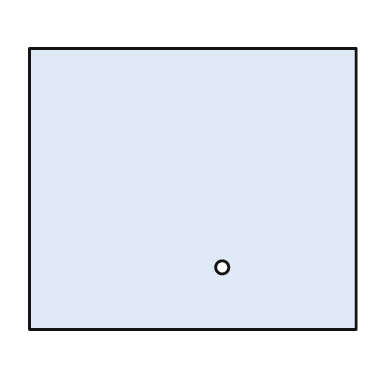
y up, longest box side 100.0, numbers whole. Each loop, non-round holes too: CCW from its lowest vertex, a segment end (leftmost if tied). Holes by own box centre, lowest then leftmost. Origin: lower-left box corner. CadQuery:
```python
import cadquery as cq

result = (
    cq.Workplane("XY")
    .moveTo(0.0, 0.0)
    .lineTo(100.0, 0.0)
    .lineTo(100.0, 86.0)
    .lineTo(0.0, 86.0)
    .close()
    .moveTo(59.0, 19.0)
    .circle(2.0)
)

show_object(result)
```